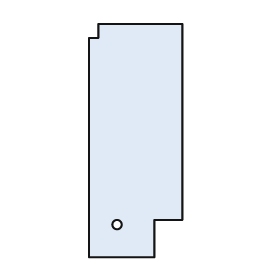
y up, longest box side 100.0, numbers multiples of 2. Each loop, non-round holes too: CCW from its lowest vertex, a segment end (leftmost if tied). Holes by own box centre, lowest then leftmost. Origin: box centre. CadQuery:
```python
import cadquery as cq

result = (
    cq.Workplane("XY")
    .moveTo(-20.0, -50.0)
    .lineTo(8.0, -50.0)
    .lineTo(8.0, -34.0)
    .lineTo(20.0, -34.0)
    .lineTo(20.0, 50.0)
    .lineTo(-16.0, 50.0)
    .lineTo(-16.0, 44.0)
    .lineTo(-20.0, 44.0)
    .close()
    .moveTo(-8.0, -36.0)
    .circle(2.0)
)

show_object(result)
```